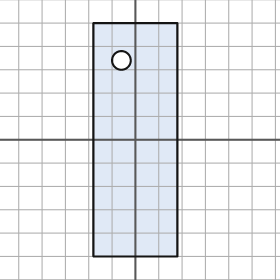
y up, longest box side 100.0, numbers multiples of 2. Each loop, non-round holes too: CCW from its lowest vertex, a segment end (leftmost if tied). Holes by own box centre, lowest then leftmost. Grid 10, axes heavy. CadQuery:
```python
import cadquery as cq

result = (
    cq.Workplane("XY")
    .moveTo(-18.0, -50.0)
    .lineTo(18.0, -50.0)
    .lineTo(18.0, 50.0)
    .lineTo(-18.0, 50.0)
    .close()
    .moveTo(-6.0, 34.0)
    .circle(4.0)
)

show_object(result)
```